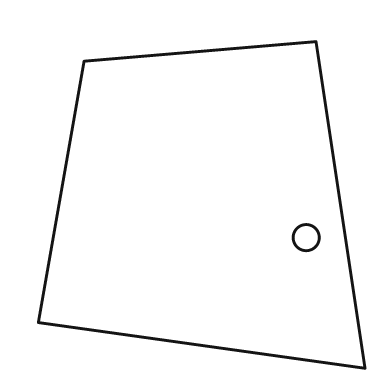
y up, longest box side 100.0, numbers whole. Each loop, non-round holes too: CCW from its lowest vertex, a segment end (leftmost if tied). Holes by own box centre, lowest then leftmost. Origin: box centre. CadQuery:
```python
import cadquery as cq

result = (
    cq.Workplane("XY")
    .moveTo(50.0, -50.0)
    .lineTo(35.0, 50.0)
    .lineTo(-36.0, 44.0)
    .lineTo(-50.0, -36.0)
    .close()
    .moveTo(32.0, -10.0)
    .circle(4.0)
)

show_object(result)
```